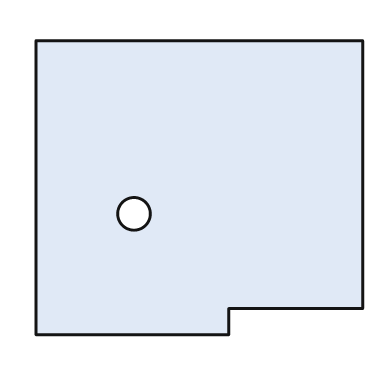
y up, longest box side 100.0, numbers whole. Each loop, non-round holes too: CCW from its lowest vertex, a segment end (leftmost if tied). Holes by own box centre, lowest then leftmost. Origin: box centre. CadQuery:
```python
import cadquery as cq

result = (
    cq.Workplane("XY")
    .moveTo(-50.0, -45.0)
    .lineTo(9.0, -45.0)
    .lineTo(9.0, -37.0)
    .lineTo(50.0, -37.0)
    .lineTo(50.0, 45.0)
    .lineTo(-50.0, 45.0)
    .close()
    .moveTo(-20.0, -8.0)
    .circle(5.0)
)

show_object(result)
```